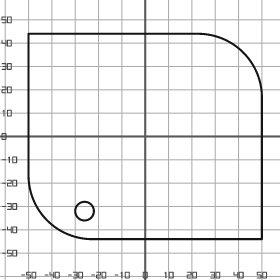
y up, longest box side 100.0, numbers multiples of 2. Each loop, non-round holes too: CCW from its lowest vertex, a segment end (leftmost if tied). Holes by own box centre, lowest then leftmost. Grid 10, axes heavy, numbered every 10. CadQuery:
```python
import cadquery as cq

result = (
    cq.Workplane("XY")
    .moveTo(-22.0, -44.0)
    .lineTo(50.0, -44.0)
    .lineTo(50.0, 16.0)
    .threePointArc((42.0, 36.0), (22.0, 44.0))
    .lineTo(-50.0, 44.0)
    .lineTo(-50.0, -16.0)
    .threePointArc((-42.0, -36.0), (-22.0, -44.0))
    .close()
    .moveTo(-26.0, -32.0)
    .circle(4.0)
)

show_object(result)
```